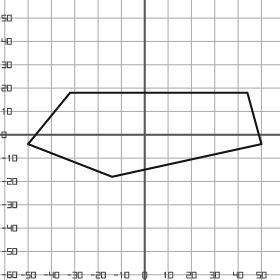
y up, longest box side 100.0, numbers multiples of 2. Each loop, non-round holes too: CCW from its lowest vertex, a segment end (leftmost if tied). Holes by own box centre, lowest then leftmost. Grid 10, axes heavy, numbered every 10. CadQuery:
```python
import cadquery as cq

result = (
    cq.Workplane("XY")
    .moveTo(-14.0, -18.0)
    .lineTo(50.0, -4.0)
    .lineTo(44.0, 18.0)
    .lineTo(-32.0, 18.0)
    .lineTo(-50.0, -4.0)
    .close()
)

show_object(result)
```